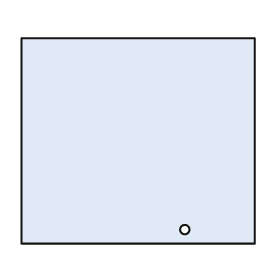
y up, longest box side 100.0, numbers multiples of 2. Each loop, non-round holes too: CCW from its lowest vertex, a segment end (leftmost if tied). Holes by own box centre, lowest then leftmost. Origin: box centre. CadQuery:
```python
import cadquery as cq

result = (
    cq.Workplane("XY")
    .moveTo(-50.0, -44.0)
    .lineTo(50.0, -44.0)
    .lineTo(50.0, 44.0)
    .lineTo(-50.0, 44.0)
    .close()
    .moveTo(20.0, -38.0)
    .circle(2.0)
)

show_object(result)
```